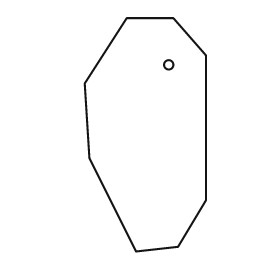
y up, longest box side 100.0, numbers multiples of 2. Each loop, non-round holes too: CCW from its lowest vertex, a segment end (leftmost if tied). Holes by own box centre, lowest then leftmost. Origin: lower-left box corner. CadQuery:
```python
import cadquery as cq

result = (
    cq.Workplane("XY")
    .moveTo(22.0, 0.0)
    .lineTo(40.0, 2.0)
    .lineTo(52.0, 22.0)
    .lineTo(52.0, 84.0)
    .lineTo(38.0, 100.0)
    .lineTo(18.0, 100.0)
    .lineTo(0.0, 72.0)
    .lineTo(2.0, 40.0)
    .close()
    .moveTo(36.0, 80.0)
    .circle(2.0)
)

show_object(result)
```